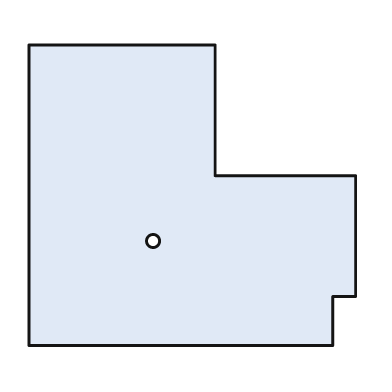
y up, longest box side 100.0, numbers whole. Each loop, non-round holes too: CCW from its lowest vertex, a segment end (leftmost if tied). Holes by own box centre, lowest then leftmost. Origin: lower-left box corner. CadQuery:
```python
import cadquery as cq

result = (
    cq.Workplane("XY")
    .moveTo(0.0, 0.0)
    .lineTo(93.0, 0.0)
    .lineTo(93.0, 15.0)
    .lineTo(100.0, 15.0)
    .lineTo(100.0, 52.0)
    .lineTo(57.0, 52.0)
    .lineTo(57.0, 92.0)
    .lineTo(0.0, 92.0)
    .close()
    .moveTo(38.0, 32.0)
    .circle(2.0)
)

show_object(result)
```